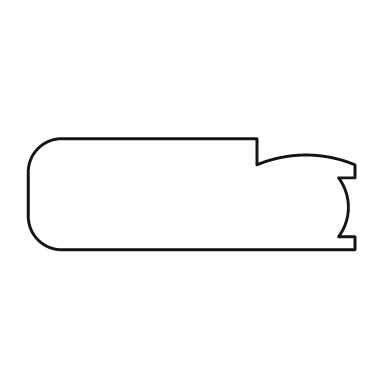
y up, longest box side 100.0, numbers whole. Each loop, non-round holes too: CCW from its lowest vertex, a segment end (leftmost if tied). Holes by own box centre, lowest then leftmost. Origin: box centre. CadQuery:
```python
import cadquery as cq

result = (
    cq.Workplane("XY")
    .moveTo(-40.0, -17.0)
    .lineTo(50.0, -17.0)
    .lineTo(50.0, -13.0)
    .lineTo(45.0, -13.0)
    .threePointArc((48.0, -4.0), (45.0, 5.0))
    .lineTo(50.0, 5.0)
    .lineTo(50.0, 9.0)
    .threePointArc((35.0, 12.0), (20.0, 9.0))
    .lineTo(20.0, 17.0)
    .lineTo(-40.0, 17.0)
    .threePointArc((-47.0, 14.0), (-50.0, 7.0))
    .lineTo(-50.0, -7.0)
    .threePointArc((-47.0, -14.0), (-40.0, -17.0))
    .close()
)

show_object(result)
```